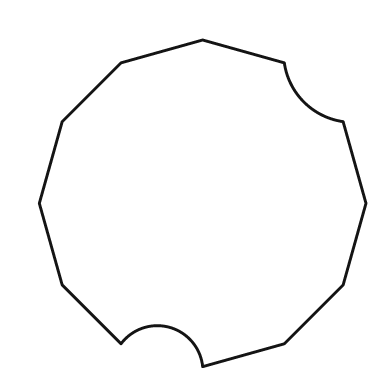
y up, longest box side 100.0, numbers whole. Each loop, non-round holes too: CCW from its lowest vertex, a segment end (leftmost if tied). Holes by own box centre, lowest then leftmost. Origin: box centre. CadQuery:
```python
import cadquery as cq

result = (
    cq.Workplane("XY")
    .moveTo(0.0, -50.0)
    .lineTo(25.0, -43.0)
    .lineTo(43.0, -25.0)
    .lineTo(50.0, 0.0)
    .lineTo(43.0, 25.0)
    .threePointArc((31.0, 31.0), (25.0, 43.0))
    .lineTo(0.0, 50.0)
    .lineTo(-25.0, 43.0)
    .lineTo(-43.0, 25.0)
    .lineTo(-50.0, 0.0)
    .lineTo(-43.0, -25.0)
    .lineTo(-25.0, -43.0)
    .threePointArc((-10.0, -38.0), (0.0, -50.0))
    .close()
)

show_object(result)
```